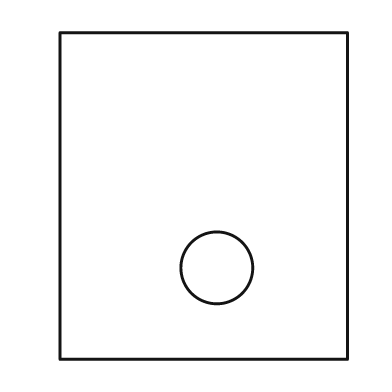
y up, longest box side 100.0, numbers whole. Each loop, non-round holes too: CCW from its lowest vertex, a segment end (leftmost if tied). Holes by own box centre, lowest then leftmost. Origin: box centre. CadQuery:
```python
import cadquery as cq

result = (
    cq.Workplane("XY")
    .moveTo(-44.0, -50.0)
    .lineTo(44.0, -50.0)
    .lineTo(44.0, 50.0)
    .lineTo(-44.0, 50.0)
    .close()
    .moveTo(4.0, -22.0)
    .circle(11.0)
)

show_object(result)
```